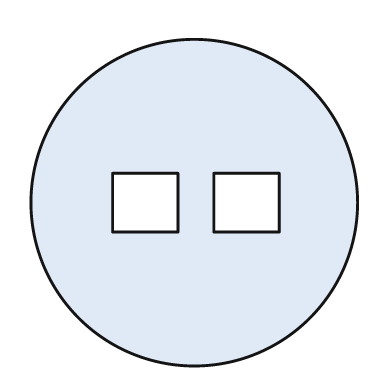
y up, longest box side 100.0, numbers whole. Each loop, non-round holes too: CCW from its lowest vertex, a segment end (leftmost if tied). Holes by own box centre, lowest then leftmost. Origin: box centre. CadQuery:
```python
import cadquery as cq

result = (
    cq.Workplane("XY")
    .moveTo(0.0, 0.0)
    .circle(50.0)
    .moveTo(-25.0, -9.0)
    .lineTo(-5.0, -9.0)
    .lineTo(-5.0, 9.0)
    .lineTo(-25.0, 9.0)
    .close()
    .moveTo(6.0, -9.0)
    .lineTo(26.0, -9.0)
    .lineTo(26.0, 9.0)
    .lineTo(6.0, 9.0)
    .close()
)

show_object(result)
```